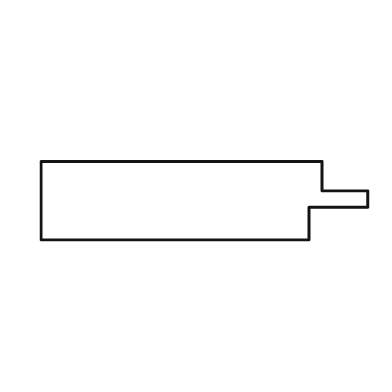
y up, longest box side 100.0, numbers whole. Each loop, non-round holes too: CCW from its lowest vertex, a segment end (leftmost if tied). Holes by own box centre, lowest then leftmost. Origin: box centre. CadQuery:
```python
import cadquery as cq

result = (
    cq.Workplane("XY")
    .moveTo(-50.0, -12.0)
    .lineTo(32.0, -12.0)
    .lineTo(32.0, -2.0)
    .lineTo(50.0, -2.0)
    .lineTo(50.0, 3.0)
    .lineTo(36.0, 3.0)
    .lineTo(36.0, 12.0)
    .lineTo(-50.0, 12.0)
    .close()
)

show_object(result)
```